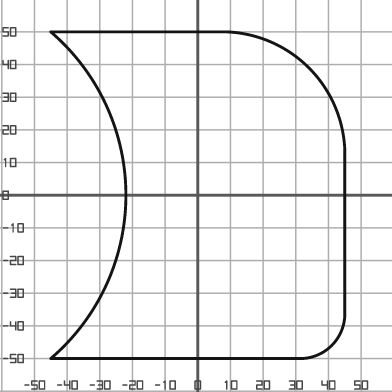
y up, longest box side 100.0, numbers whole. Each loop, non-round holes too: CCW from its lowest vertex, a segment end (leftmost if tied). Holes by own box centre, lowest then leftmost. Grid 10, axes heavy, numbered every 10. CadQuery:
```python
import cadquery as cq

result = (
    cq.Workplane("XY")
    .moveTo(-45.0, -50.0)
    .lineTo(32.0, -50.0)
    .threePointArc((41.0, -46.0), (45.0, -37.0))
    .lineTo(45.0, 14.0)
    .threePointArc((34.0, 39.0), (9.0, 50.0))
    .lineTo(-45.0, 50.0)
    .threePointArc((-22.0, 0.0), (-45.0, -50.0))
    .close()
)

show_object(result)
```